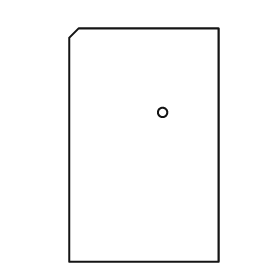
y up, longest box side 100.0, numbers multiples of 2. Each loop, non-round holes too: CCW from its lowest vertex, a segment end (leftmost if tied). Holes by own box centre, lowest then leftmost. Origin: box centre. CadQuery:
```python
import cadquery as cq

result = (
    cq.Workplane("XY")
    .moveTo(-32.0, -50.0)
    .lineTo(32.0, -50.0)
    .lineTo(32.0, 50.0)
    .lineTo(-28.0, 50.0)
    .lineTo(-32.0, 46.0)
    .close()
    .moveTo(8.0, 14.0)
    .circle(2.0)
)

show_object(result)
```